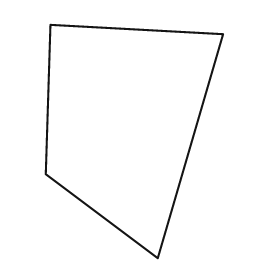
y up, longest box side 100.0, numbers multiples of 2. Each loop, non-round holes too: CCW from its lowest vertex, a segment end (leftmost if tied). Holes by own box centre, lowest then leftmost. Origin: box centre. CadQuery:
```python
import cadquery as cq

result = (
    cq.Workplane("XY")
    .moveTo(10.0, -50.0)
    .lineTo(38.0, 46.0)
    .lineTo(-36.0, 50.0)
    .lineTo(-38.0, -14.0)
    .close()
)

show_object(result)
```